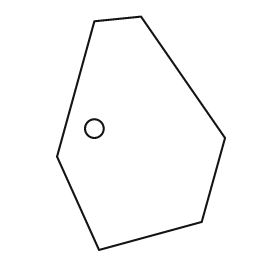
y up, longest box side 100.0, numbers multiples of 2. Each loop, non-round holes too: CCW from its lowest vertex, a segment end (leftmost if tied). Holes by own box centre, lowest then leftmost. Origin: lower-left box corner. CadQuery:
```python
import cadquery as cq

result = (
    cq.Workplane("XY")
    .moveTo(18.0, 0.0)
    .lineTo(62.0, 12.0)
    .lineTo(72.0, 48.0)
    .lineTo(36.0, 100.0)
    .lineTo(16.0, 98.0)
    .lineTo(0.0, 40.0)
    .close()
    .moveTo(16.0, 52.0)
    .circle(4.0)
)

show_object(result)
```